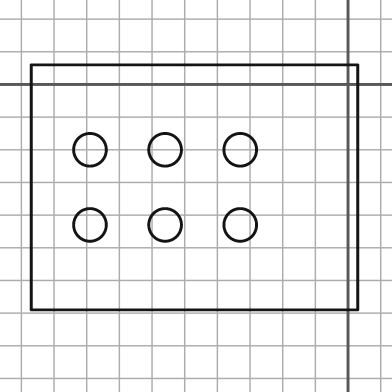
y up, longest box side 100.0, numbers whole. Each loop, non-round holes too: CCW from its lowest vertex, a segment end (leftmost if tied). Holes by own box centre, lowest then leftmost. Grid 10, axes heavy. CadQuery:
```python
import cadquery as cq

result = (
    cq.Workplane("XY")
    .moveTo(-97.0, -69.0)
    .lineTo(3.0, -69.0)
    .lineTo(3.0, 6.0)
    .lineTo(-97.0, 6.0)
    .close()
    .moveTo(-79.0, -43.0)
    .circle(5.0)
    .moveTo(-56.0, -43.0)
    .circle(5.0)
    .moveTo(-33.0, -43.0)
    .circle(5.0)
    .moveTo(-79.0, -20.0)
    .circle(5.0)
    .moveTo(-56.0, -20.0)
    .circle(5.0)
    .moveTo(-33.0, -20.0)
    .circle(5.0)
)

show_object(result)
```